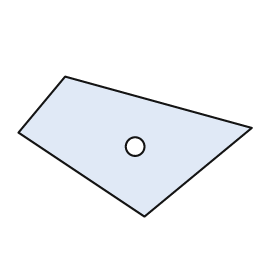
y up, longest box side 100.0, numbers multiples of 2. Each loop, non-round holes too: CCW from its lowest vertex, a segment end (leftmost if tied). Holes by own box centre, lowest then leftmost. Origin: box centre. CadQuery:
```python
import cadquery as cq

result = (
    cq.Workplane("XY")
    .moveTo(4.0, -30.0)
    .lineTo(50.0, 8.0)
    .lineTo(-30.0, 30.0)
    .lineTo(-50.0, 6.0)
    .close()
    .moveTo(0.0, 0.0)
    .circle(4.0)
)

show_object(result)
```